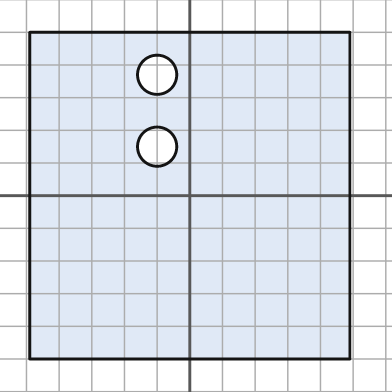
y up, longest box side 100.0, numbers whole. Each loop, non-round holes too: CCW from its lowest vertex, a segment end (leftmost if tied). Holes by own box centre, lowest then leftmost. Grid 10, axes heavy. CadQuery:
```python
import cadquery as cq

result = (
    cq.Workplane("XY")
    .moveTo(-49.0, -50.0)
    .lineTo(49.0, -50.0)
    .lineTo(49.0, 50.0)
    .lineTo(-49.0, 50.0)
    .close()
    .moveTo(-10.0, 15.0)
    .circle(6.0)
    .moveTo(-10.0, 37.0)
    .circle(6.0)
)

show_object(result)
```